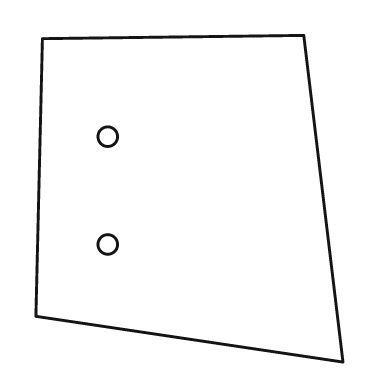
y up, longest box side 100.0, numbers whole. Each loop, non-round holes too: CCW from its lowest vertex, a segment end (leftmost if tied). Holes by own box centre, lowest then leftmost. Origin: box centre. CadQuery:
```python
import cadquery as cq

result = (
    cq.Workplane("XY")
    .moveTo(47.0, -50.0)
    .lineTo(35.0, 50.0)
    .lineTo(-45.0, 49.0)
    .lineTo(-47.0, -36.0)
    .close()
    .moveTo(-25.0, -14.0)
    .circle(3.0)
    .moveTo(-25.0, 19.0)
    .circle(3.0)
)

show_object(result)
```